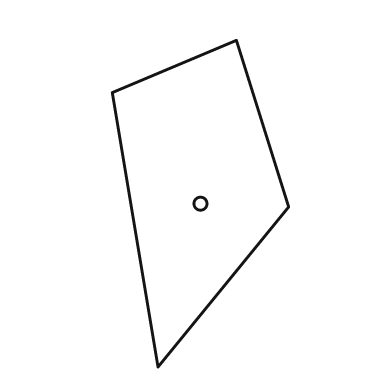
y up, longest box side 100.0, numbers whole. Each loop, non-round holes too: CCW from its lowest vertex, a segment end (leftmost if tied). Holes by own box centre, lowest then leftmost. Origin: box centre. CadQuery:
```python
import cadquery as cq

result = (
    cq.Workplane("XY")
    .moveTo(-13.0, -50.0)
    .lineTo(27.0, -1.0)
    .lineTo(11.0, 50.0)
    .lineTo(-27.0, 34.0)
    .close()
    .moveTo(0.0, 0.0)
    .circle(2.0)
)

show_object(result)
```